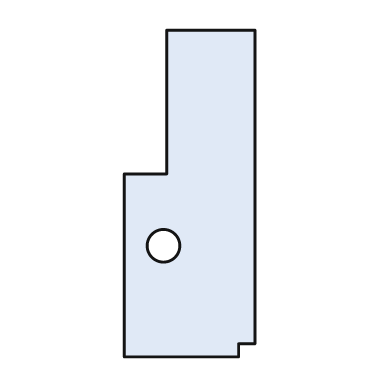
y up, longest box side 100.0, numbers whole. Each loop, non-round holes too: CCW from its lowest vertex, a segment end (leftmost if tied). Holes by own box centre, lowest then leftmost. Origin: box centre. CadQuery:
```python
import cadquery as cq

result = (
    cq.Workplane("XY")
    .moveTo(-20.0, -50.0)
    .lineTo(15.0, -50.0)
    .lineTo(15.0, -46.0)
    .lineTo(20.0, -46.0)
    .lineTo(20.0, 50.0)
    .lineTo(-7.0, 50.0)
    .lineTo(-7.0, 6.0)
    .lineTo(-20.0, 6.0)
    .close()
    .moveTo(-8.0, -16.0)
    .circle(5.0)
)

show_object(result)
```